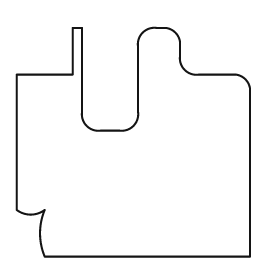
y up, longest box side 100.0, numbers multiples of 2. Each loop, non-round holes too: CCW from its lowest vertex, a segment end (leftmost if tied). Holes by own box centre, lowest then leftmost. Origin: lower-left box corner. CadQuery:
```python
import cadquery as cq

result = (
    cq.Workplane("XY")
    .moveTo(12.0, 0.0)
    .lineTo(100.0, 0.0)
    .lineTo(100.0, 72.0)
    .threePointArc((98.0, 76.0), (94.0, 78.0))
    .lineTo(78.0, 78.0)
    .threePointArc((72.0, 80.0), (70.0, 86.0))
    .lineTo(70.0, 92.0)
    .threePointArc((68.0, 96.0), (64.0, 98.0))
    .lineTo(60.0, 98.0)
    .threePointArc((54.0, 96.0), (52.0, 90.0))
    .lineTo(52.0, 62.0)
    .threePointArc((50.0, 56.0), (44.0, 54.0))
    .lineTo(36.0, 54.0)
    .threePointArc((30.0, 56.0), (28.0, 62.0))
    .lineTo(28.0, 98.0)
    .lineTo(24.0, 98.0)
    .lineTo(24.0, 78.0)
    .lineTo(0.0, 78.0)
    .lineTo(0.0, 20.0)
    .threePointArc((6.0, 18.0), (12.0, 20.0))
    .threePointArc((10.0, 10.0), (12.0, 0.0))
    .close()
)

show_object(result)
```